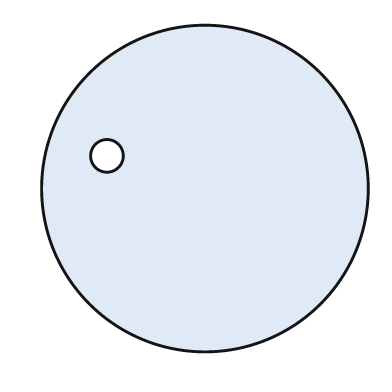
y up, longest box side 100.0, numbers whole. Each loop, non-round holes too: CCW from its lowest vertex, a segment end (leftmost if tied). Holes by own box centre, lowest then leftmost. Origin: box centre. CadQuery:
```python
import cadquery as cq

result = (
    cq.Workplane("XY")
    .moveTo(0.0, 0.0)
    .circle(50.0)
    .moveTo(-30.0, 10.0)
    .circle(5.0)
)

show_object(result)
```